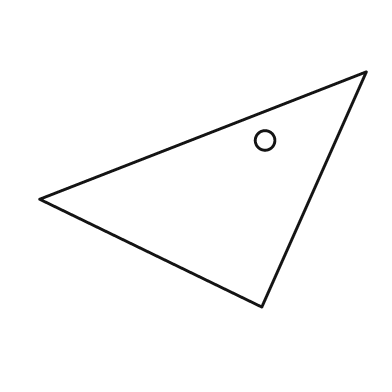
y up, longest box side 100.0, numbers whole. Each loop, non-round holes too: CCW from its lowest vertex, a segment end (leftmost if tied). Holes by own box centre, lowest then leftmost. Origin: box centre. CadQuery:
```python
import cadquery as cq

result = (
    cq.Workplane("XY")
    .moveTo(18.0, -36.0)
    .lineTo(50.0, 36.0)
    .lineTo(-50.0, -3.0)
    .close()
    .moveTo(19.0, 15.0)
    .circle(3.0)
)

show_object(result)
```